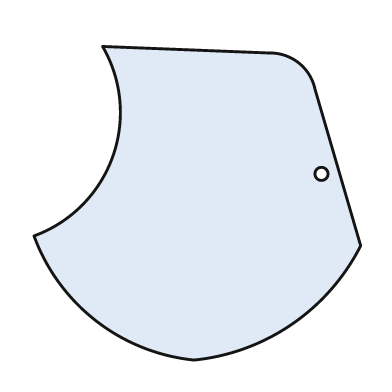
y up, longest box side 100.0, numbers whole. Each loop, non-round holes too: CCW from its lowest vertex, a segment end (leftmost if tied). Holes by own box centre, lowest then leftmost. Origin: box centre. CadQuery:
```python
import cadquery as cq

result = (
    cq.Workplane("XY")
    .moveTo(-1.0, -48.0)
    .threePointArc((29.0, -37.0), (50.0, -13.0))
    .lineTo(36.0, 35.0)
    .threePointArc((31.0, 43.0), (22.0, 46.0))
    .lineTo(-29.0, 48.0)
    .threePointArc((-26.0, 14.0), (-50.0, -10.0))
    .threePointArc((-31.0, -36.0), (-1.0, -48.0))
    .close()
    .moveTo(38.0, 9.0)
    .circle(2.0)
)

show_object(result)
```